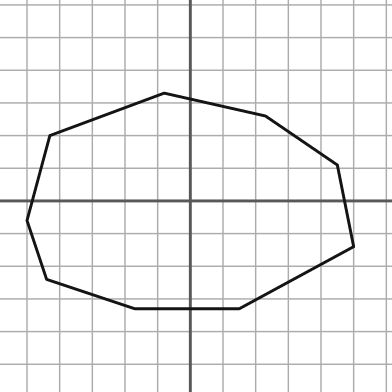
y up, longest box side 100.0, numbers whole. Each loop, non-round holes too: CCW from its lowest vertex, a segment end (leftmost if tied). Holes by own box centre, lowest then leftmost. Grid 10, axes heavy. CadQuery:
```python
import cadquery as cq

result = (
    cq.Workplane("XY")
    .moveTo(-17.0, -33.0)
    .lineTo(15.0, -33.0)
    .lineTo(50.0, -14.0)
    .lineTo(45.0, 11.0)
    .lineTo(23.0, 26.0)
    .lineTo(-8.0, 33.0)
    .lineTo(-43.0, 20.0)
    .lineTo(-50.0, -6.0)
    .lineTo(-44.0, -24.0)
    .close()
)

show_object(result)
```